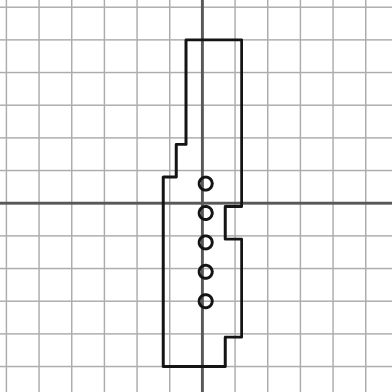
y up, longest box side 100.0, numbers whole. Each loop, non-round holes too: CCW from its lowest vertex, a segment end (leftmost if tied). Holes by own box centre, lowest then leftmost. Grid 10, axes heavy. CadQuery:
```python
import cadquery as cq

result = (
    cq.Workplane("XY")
    .moveTo(-12.0, -50.0)
    .lineTo(7.0, -50.0)
    .lineTo(7.0, -41.0)
    .lineTo(12.0, -41.0)
    .lineTo(12.0, -11.0)
    .lineTo(7.0, -11.0)
    .lineTo(7.0, -1.0)
    .lineTo(12.0, -1.0)
    .lineTo(12.0, 50.0)
    .lineTo(-5.0, 50.0)
    .lineTo(-5.0, 18.0)
    .lineTo(-8.0, 18.0)
    .lineTo(-8.0, 8.0)
    .lineTo(-12.0, 8.0)
    .close()
    .moveTo(1.0, -30.0)
    .circle(2.0)
    .moveTo(1.0, -21.0)
    .circle(2.0)
    .moveTo(1.0, -12.0)
    .circle(2.0)
    .moveTo(1.0, -3.0)
    .circle(2.0)
    .moveTo(1.0, 6.0)
    .circle(2.0)
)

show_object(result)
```